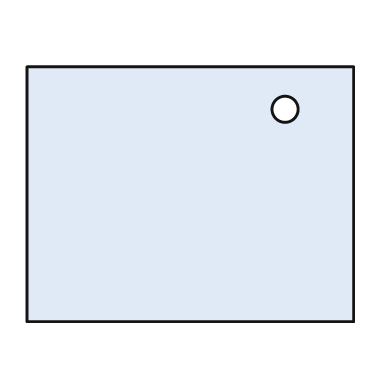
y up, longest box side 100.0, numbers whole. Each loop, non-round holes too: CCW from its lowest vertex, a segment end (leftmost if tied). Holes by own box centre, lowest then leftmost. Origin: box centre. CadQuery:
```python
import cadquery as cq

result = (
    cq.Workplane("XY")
    .moveTo(-50.0, -39.0)
    .lineTo(50.0, -39.0)
    .lineTo(50.0, 39.0)
    .lineTo(-50.0, 39.0)
    .close()
    .moveTo(29.0, 26.0)
    .circle(4.0)
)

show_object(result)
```